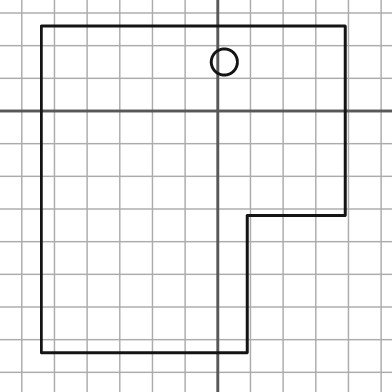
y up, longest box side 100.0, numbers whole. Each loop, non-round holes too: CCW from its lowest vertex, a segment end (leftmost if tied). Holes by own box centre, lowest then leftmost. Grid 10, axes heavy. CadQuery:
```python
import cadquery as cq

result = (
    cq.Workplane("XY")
    .moveTo(-54.0, -74.0)
    .lineTo(9.0, -74.0)
    .lineTo(9.0, -32.0)
    .lineTo(39.0, -32.0)
    .lineTo(39.0, 26.0)
    .lineTo(-54.0, 26.0)
    .close()
    .moveTo(2.0, 15.0)
    .circle(4.0)
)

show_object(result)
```